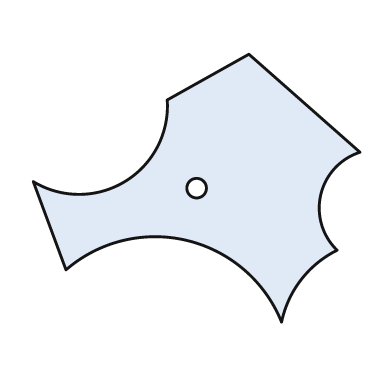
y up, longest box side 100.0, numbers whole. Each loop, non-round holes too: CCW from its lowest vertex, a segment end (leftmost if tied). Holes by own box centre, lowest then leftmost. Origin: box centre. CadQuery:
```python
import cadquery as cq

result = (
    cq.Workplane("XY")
    .moveTo(26.0, -41.0)
    .threePointArc((32.0, -28.0), (43.0, -19.0))
    .threePointArc((38.0, -2.0), (50.0, 11.0))
    .lineTo(16.0, 41.0)
    .lineTo(-9.0, 27.0)
    .threePointArc((-22.0, 2.0), (-50.0, 2.0))
    .lineTo(-40.0, -25.0)
    .threePointArc((-3.0, -16.0), (26.0, -41.0))
    .close()
    .moveTo(0.0, 0.0)
    .circle(3.0)
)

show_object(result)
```